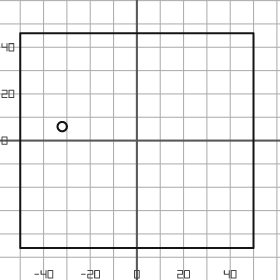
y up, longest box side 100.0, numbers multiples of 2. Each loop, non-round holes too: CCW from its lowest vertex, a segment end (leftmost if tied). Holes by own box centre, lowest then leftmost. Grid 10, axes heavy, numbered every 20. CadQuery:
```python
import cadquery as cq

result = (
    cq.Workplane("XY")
    .moveTo(-50.0, -46.0)
    .lineTo(50.0, -46.0)
    .lineTo(50.0, 46.0)
    .lineTo(-50.0, 46.0)
    .close()
    .moveTo(-32.0, 6.0)
    .circle(2.0)
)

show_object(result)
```